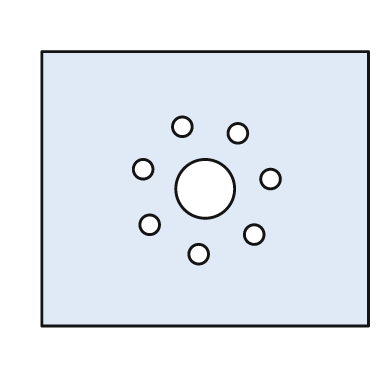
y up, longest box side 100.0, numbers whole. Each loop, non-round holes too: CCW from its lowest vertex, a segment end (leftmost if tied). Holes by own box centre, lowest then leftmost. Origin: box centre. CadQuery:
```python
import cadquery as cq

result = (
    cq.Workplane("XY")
    .moveTo(-50.0, -42.0)
    .lineTo(50.0, -42.0)
    .lineTo(50.0, 42.0)
    .lineTo(-50.0, 42.0)
    .close()
    .moveTo(-2.0, -20.0)
    .circle(3.0)
    .moveTo(15.0, -14.0)
    .circle(3.0)
    .moveTo(-17.0, -11.0)
    .circle(3.0)
    .moveTo(0.0, 0.0)
    .circle(9.0)
    .moveTo(20.0, 3.0)
    .circle(3.0)
    .moveTo(-19.0, 6.0)
    .circle(3.0)
    .moveTo(10.0, 17.0)
    .circle(3.0)
    .moveTo(-7.0, 19.0)
    .circle(3.0)
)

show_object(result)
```